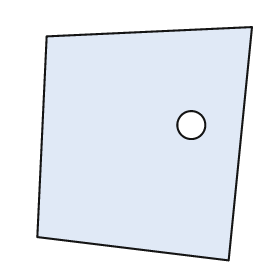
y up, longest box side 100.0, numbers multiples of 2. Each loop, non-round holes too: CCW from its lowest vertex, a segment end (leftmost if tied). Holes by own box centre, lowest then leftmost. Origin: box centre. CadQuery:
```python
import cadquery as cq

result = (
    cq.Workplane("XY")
    .moveTo(36.0, -50.0)
    .lineTo(46.0, 50.0)
    .lineTo(-42.0, 46.0)
    .lineTo(-46.0, -40.0)
    .close()
    .moveTo(20.0, 8.0)
    .circle(6.0)
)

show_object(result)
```